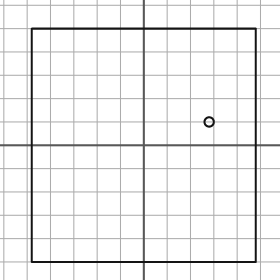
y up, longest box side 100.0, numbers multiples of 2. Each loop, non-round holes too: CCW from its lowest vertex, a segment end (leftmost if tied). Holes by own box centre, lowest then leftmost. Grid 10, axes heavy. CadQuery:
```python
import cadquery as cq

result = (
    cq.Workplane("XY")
    .moveTo(-48.0, -50.0)
    .lineTo(48.0, -50.0)
    .lineTo(48.0, 50.0)
    .lineTo(-48.0, 50.0)
    .close()
    .moveTo(28.0, 10.0)
    .circle(2.0)
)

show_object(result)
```